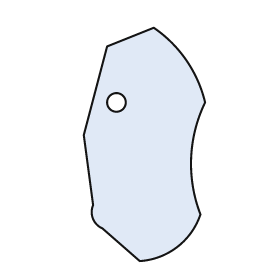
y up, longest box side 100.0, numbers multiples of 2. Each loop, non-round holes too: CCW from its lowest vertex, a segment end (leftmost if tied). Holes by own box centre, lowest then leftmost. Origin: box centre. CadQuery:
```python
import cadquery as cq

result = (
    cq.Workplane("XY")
    .moveTo(-2.0, -50.0)
    .threePointArc((14.0, -44.0), (24.0, -30.0))
    .threePointArc((20.0, -6.0), (26.0, 18.0))
    .threePointArc((18.0, 36.0), (4.0, 50.0))
    .lineTo(-16.0, 42.0)
    .lineTo(-26.0, 4.0)
    .lineTo(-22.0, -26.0)
    .threePointArc((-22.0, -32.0), (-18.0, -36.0))
    .close()
    .moveTo(-12.0, 18.0)
    .circle(4.0)
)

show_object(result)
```